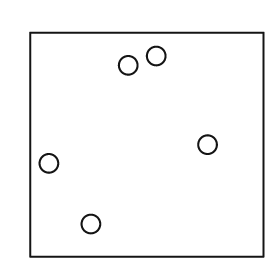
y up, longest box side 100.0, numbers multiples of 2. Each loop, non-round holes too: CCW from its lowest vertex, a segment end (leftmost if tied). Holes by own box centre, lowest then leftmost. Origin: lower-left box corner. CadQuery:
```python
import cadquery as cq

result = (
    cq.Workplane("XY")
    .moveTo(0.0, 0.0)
    .lineTo(100.0, 0.0)
    .lineTo(100.0, 96.0)
    .lineTo(0.0, 96.0)
    .close()
    .moveTo(26.0, 14.0)
    .circle(4.0)
    .moveTo(8.0, 40.0)
    .circle(4.0)
    .moveTo(76.0, 48.0)
    .circle(4.0)
    .moveTo(42.0, 82.0)
    .circle(4.0)
    .moveTo(54.0, 86.0)
    .circle(4.0)
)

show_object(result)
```